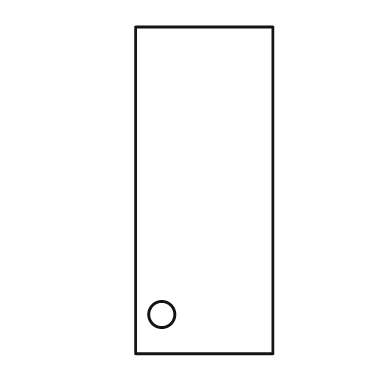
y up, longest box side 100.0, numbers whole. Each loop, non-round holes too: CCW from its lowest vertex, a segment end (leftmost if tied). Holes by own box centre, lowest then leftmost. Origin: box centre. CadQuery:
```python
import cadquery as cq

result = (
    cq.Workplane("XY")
    .moveTo(-21.0, -50.0)
    .lineTo(21.0, -50.0)
    .lineTo(21.0, 50.0)
    .lineTo(-21.0, 50.0)
    .close()
    .moveTo(-13.0, -38.0)
    .circle(4.0)
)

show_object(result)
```